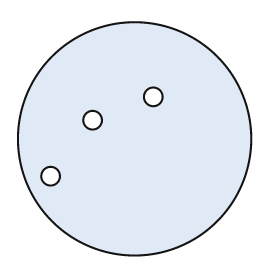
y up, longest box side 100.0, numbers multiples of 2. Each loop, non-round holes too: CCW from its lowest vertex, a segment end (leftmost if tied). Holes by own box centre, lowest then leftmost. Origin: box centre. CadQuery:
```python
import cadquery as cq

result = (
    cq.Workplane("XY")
    .moveTo(0.0, 0.0)
    .circle(50.0)
    .moveTo(-36.0, -16.0)
    .circle(4.0)
    .moveTo(-18.0, 8.0)
    .circle(4.0)
    .moveTo(8.0, 18.0)
    .circle(4.0)
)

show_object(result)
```